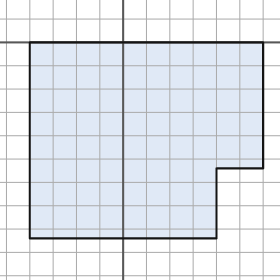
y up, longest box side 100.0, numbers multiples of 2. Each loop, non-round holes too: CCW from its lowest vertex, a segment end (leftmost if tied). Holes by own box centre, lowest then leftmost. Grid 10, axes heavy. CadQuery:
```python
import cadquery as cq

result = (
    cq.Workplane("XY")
    .moveTo(-40.0, -84.0)
    .lineTo(40.0, -84.0)
    .lineTo(40.0, -54.0)
    .lineTo(60.0, -54.0)
    .lineTo(60.0, 0.0)
    .lineTo(-40.0, 0.0)
    .close()
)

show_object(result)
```